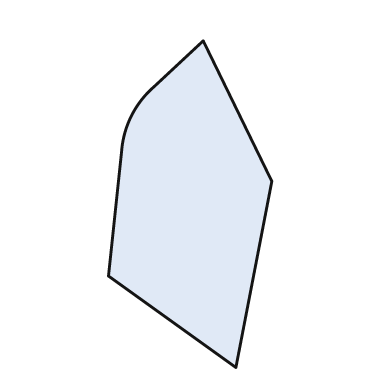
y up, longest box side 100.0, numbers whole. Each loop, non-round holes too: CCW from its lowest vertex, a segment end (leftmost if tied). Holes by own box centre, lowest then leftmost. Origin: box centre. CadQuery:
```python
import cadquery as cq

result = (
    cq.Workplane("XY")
    .moveTo(14.0, -50.0)
    .lineTo(25.0, 7.0)
    .lineTo(4.0, 50.0)
    .lineTo(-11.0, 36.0)
    .threePointArc((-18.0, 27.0), (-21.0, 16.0))
    .lineTo(-25.0, -22.0)
    .close()
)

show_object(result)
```